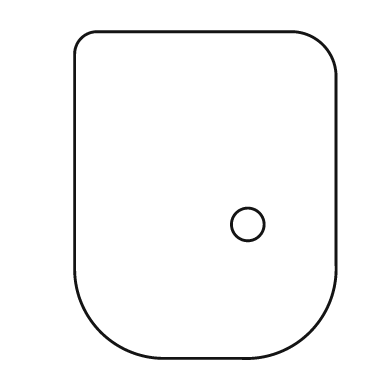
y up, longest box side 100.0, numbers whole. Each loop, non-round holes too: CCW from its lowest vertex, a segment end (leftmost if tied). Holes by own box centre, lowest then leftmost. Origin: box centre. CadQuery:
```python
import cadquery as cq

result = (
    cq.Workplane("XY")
    .moveTo(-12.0, -50.0)
    .lineTo(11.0, -50.0)
    .threePointArc((32.0, -42.0), (40.0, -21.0))
    .lineTo(40.0, 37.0)
    .threePointArc((36.0, 46.0), (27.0, 50.0))
    .lineTo(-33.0, 50.0)
    .threePointArc((-38.0, 48.0), (-40.0, 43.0))
    .lineTo(-40.0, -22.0)
    .threePointArc((-32.0, -42.0), (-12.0, -50.0))
    .close()
    .moveTo(13.0, -9.0)
    .circle(5.0)
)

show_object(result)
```